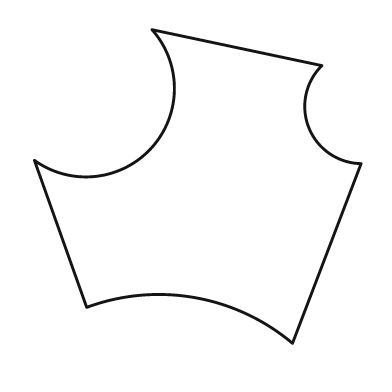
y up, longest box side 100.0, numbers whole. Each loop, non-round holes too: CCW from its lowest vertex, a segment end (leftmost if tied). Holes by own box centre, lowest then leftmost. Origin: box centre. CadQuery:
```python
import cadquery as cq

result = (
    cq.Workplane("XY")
    .moveTo(29.0, -48.0)
    .lineTo(50.0, 7.0)
    .threePointArc((34.0, 18.0), (38.0, 37.0))
    .lineTo(-14.0, 48.0)
    .threePointArc((-14.0, 12.0), (-50.0, 8.0))
    .lineTo(-34.0, -37.0)
    .threePointArc((-1.0, -34.0), (29.0, -48.0))
    .close()
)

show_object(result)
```